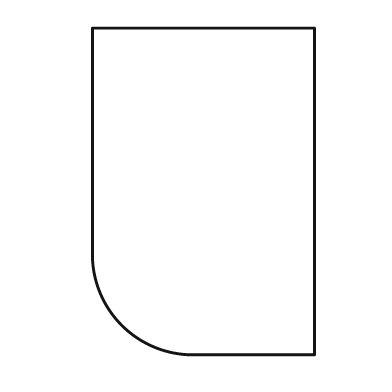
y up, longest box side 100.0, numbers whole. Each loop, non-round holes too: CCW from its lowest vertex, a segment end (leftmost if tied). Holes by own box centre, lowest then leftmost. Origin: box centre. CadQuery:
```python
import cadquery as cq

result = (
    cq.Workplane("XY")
    .moveTo(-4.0, -50.0)
    .lineTo(34.0, -50.0)
    .lineTo(34.0, 50.0)
    .lineTo(-34.0, 50.0)
    .lineTo(-34.0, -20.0)
    .threePointArc((-25.0, -41.0), (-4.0, -50.0))
    .close()
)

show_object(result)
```